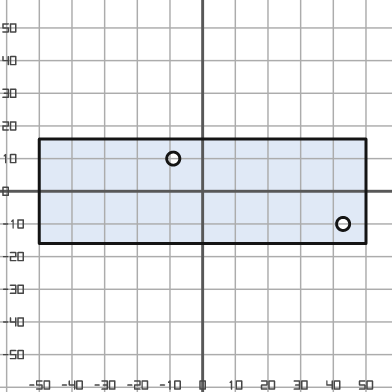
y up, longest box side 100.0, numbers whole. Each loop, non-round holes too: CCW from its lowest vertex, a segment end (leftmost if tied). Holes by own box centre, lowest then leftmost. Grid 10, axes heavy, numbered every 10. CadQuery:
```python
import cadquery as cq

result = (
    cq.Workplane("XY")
    .moveTo(-50.0, -16.0)
    .lineTo(50.0, -16.0)
    .lineTo(50.0, 16.0)
    .lineTo(-50.0, 16.0)
    .close()
    .moveTo(43.0, -10.0)
    .circle(2.0)
    .moveTo(-9.0, 10.0)
    .circle(2.0)
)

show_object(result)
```